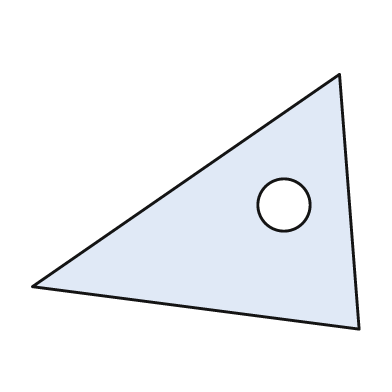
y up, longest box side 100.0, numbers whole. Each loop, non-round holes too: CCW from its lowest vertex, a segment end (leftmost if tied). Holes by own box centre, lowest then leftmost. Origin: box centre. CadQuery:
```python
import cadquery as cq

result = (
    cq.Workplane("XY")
    .moveTo(50.0, -39.0)
    .lineTo(44.0, 39.0)
    .lineTo(-50.0, -26.0)
    .close()
    .moveTo(27.0, -1.0)
    .circle(8.0)
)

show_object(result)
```